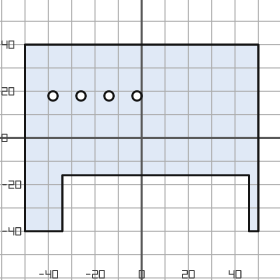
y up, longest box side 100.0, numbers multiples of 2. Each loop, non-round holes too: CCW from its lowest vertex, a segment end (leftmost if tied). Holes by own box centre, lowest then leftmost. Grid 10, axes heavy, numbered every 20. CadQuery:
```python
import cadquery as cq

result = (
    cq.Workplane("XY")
    .moveTo(-50.0, -40.0)
    .lineTo(-34.0, -40.0)
    .lineTo(-34.0, -16.0)
    .lineTo(46.0, -16.0)
    .lineTo(46.0, -40.0)
    .lineTo(50.0, -40.0)
    .lineTo(50.0, 40.0)
    .lineTo(-50.0, 40.0)
    .close()
    .moveTo(-38.0, 18.0)
    .circle(2.0)
    .moveTo(-26.0, 18.0)
    .circle(2.0)
    .moveTo(-14.0, 18.0)
    .circle(2.0)
    .moveTo(-2.0, 18.0)
    .circle(2.0)
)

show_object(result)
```